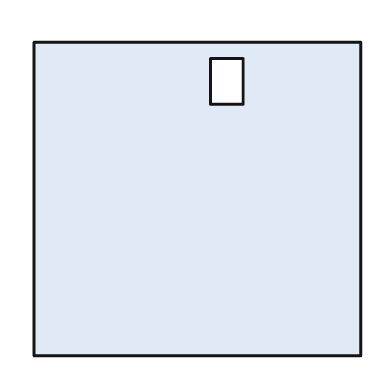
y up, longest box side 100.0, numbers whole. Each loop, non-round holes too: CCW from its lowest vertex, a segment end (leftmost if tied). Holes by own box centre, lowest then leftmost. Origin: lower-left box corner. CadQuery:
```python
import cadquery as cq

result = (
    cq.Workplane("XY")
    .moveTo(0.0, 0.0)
    .lineTo(100.0, 0.0)
    .lineTo(100.0, 96.0)
    .lineTo(0.0, 96.0)
    .close()
    .moveTo(54.0, 77.0)
    .lineTo(64.0, 77.0)
    .lineTo(64.0, 91.0)
    .lineTo(54.0, 91.0)
    .close()
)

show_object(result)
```